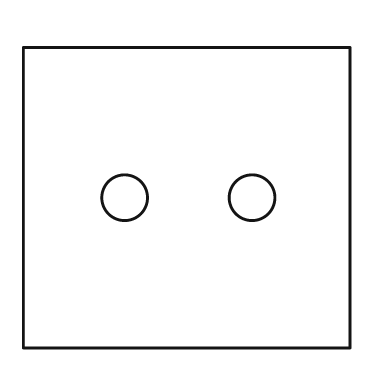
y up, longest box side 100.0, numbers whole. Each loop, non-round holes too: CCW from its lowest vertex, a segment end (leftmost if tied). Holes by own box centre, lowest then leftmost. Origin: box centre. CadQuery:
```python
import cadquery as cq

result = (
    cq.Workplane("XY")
    .moveTo(-50.0, -46.0)
    .lineTo(50.0, -46.0)
    .lineTo(50.0, 46.0)
    .lineTo(-50.0, 46.0)
    .close()
    .moveTo(-19.0, 0.0)
    .circle(7.0)
    .moveTo(20.0, 0.0)
    .circle(7.0)
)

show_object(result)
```